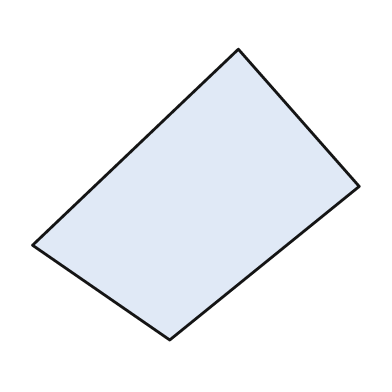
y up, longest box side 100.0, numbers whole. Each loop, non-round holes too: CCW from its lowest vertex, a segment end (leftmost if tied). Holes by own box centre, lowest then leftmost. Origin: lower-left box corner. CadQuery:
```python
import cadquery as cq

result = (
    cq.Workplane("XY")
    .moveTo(42.0, 0.0)
    .lineTo(100.0, 47.0)
    .lineTo(63.0, 89.0)
    .lineTo(0.0, 29.0)
    .close()
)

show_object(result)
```